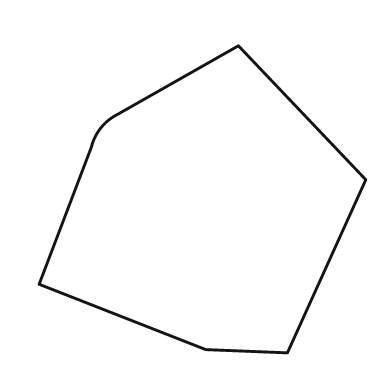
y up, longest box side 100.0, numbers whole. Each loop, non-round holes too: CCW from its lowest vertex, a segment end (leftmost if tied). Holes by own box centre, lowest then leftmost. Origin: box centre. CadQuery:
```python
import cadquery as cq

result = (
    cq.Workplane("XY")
    .moveTo(26.0, -47.0)
    .lineTo(50.0, 6.0)
    .lineTo(11.0, 47.0)
    .lineTo(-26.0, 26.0)
    .threePointArc((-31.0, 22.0), (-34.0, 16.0))
    .lineTo(-50.0, -26.0)
    .lineTo(1.0, -46.0)
    .close()
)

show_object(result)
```